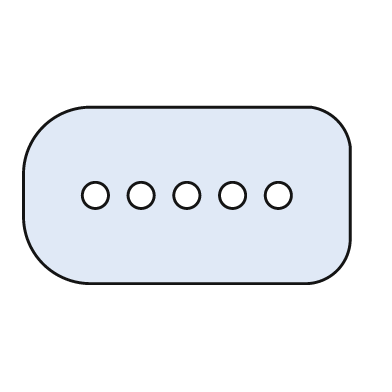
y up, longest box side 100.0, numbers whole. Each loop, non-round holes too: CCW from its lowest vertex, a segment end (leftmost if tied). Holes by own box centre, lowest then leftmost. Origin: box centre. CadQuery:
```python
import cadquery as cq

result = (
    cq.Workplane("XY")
    .moveTo(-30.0, -27.0)
    .lineTo(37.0, -27.0)
    .threePointArc((46.0, -23.0), (50.0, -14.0))
    .lineTo(50.0, 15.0)
    .threePointArc((46.0, 23.0), (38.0, 27.0))
    .lineTo(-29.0, 27.0)
    .threePointArc((-44.0, 21.0), (-50.0, 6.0))
    .lineTo(-50.0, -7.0)
    .threePointArc((-44.0, -21.0), (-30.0, -27.0))
    .close()
    .moveTo(-28.0, 0.0)
    .circle(4.0)
    .moveTo(-14.0, 0.0)
    .circle(4.0)
    .moveTo(0.0, 0.0)
    .circle(4.0)
    .moveTo(14.0, 0.0)
    .circle(4.0)
    .moveTo(28.0, 0.0)
    .circle(4.0)
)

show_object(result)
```